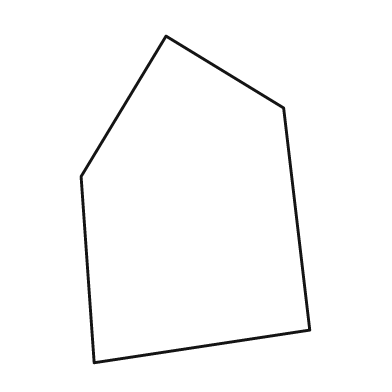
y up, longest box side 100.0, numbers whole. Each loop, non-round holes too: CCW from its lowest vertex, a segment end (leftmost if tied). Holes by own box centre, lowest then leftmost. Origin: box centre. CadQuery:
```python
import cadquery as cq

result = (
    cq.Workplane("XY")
    .moveTo(-31.0, -50.0)
    .lineTo(35.0, -40.0)
    .lineTo(27.0, 28.0)
    .lineTo(-9.0, 50.0)
    .lineTo(-35.0, 7.0)
    .close()
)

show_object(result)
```